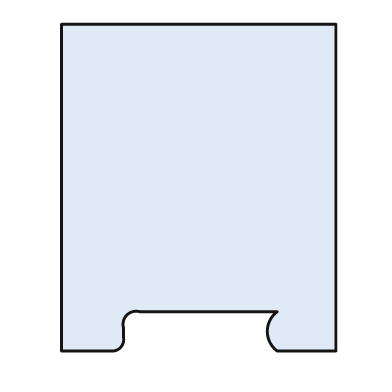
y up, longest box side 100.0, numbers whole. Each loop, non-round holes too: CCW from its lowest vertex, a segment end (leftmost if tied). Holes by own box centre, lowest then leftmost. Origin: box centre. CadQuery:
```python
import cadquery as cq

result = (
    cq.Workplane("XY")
    .moveTo(-42.0, -50.0)
    .lineTo(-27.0, -50.0)
    .threePointArc((-24.0, -49.0), (-23.0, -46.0))
    .lineTo(-23.0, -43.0)
    .threePointArc((-22.0, -39.0), (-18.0, -38.0))
    .lineTo(24.0, -38.0)
    .threePointArc((21.0, -44.0), (24.0, -50.0))
    .lineTo(42.0, -50.0)
    .lineTo(42.0, 50.0)
    .lineTo(-42.0, 50.0)
    .close()
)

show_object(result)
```